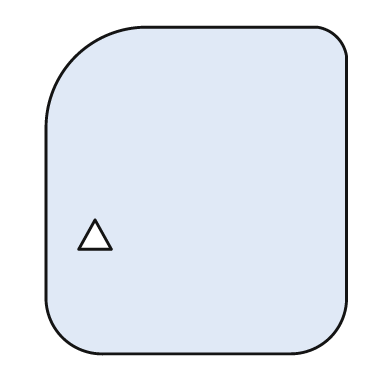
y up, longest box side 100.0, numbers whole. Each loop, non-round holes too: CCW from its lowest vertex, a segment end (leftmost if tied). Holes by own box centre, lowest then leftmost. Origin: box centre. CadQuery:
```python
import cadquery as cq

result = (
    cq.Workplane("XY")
    .moveTo(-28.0, -50.0)
    .lineTo(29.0, -50.0)
    .threePointArc((41.0, -45.0), (46.0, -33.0))
    .lineTo(46.0, 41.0)
    .threePointArc((43.0, 47.0), (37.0, 50.0))
    .lineTo(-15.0, 50.0)
    .threePointArc((-37.0, 41.0), (-46.0, 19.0))
    .lineTo(-46.0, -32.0)
    .threePointArc((-41.0, -45.0), (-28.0, -50.0))
    .close()
    .moveTo(-36.0, -18.0)
    .lineTo(-26.0, -18.0)
    .lineTo(-31.0, -9.0)
    .close()
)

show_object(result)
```